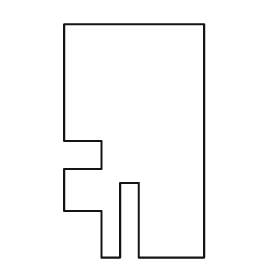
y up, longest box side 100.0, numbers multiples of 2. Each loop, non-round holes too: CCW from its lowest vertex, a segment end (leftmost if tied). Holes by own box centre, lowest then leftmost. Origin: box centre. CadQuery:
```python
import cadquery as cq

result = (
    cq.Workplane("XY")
    .moveTo(-14.0, -50.0)
    .lineTo(-6.0, -50.0)
    .lineTo(-6.0, -18.0)
    .lineTo(2.0, -18.0)
    .lineTo(2.0, -50.0)
    .lineTo(30.0, -50.0)
    .lineTo(30.0, 50.0)
    .lineTo(-30.0, 50.0)
    .lineTo(-30.0, 0.0)
    .lineTo(-14.0, 0.0)
    .lineTo(-14.0, -12.0)
    .lineTo(-30.0, -12.0)
    .lineTo(-30.0, -30.0)
    .lineTo(-14.0, -30.0)
    .close()
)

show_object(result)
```